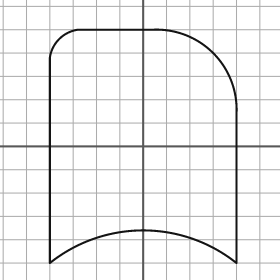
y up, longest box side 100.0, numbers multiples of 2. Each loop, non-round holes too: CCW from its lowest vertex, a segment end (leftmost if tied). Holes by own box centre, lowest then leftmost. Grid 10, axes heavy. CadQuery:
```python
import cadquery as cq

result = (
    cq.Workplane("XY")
    .moveTo(-40.0, -50.0)
    .threePointArc((0.0, -36.0), (40.0, -50.0))
    .lineTo(40.0, 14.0)
    .threePointArc((30.0, 40.0), (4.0, 50.0))
    .lineTo(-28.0, 50.0)
    .threePointArc((-36.0, 46.0), (-40.0, 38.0))
    .close()
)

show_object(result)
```